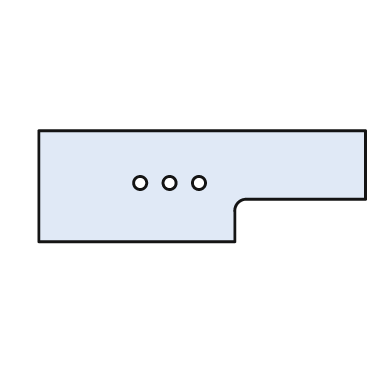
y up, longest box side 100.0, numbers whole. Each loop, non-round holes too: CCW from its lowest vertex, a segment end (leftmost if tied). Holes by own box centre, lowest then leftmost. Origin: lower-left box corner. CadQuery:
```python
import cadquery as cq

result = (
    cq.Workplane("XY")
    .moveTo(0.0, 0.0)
    .lineTo(60.0, 0.0)
    .lineTo(60.0, 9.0)
    .threePointArc((61.0, 12.0), (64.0, 13.0))
    .lineTo(100.0, 13.0)
    .lineTo(100.0, 34.0)
    .lineTo(0.0, 34.0)
    .close()
    .moveTo(31.0, 18.0)
    .circle(2.0)
    .moveTo(40.0, 18.0)
    .circle(2.0)
    .moveTo(49.0, 18.0)
    .circle(2.0)
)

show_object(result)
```